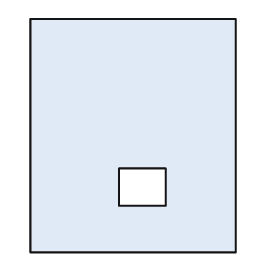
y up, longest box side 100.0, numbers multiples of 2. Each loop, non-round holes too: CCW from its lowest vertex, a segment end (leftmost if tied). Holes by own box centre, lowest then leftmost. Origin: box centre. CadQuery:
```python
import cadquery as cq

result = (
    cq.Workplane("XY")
    .moveTo(-44.0, -50.0)
    .lineTo(44.0, -50.0)
    .lineTo(44.0, 50.0)
    .lineTo(-44.0, 50.0)
    .close()
    .moveTo(-6.0, -30.0)
    .lineTo(14.0, -30.0)
    .lineTo(14.0, -14.0)
    .lineTo(-6.0, -14.0)
    .close()
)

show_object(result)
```